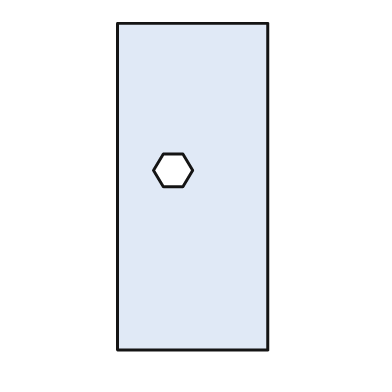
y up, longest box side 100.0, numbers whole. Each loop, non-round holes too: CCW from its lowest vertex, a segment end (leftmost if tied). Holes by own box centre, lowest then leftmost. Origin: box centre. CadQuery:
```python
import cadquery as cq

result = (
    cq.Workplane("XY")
    .moveTo(-23.0, -50.0)
    .lineTo(23.0, -50.0)
    .lineTo(23.0, 50.0)
    .lineTo(-23.0, 50.0)
    .close()
    .moveTo(-9.0, 0.0)
    .lineTo(-3.0, 0.0)
    .lineTo(0.0, 5.0)
    .lineTo(-3.0, 10.0)
    .lineTo(-9.0, 10.0)
    .lineTo(-12.0, 5.0)
    .close()
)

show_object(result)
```